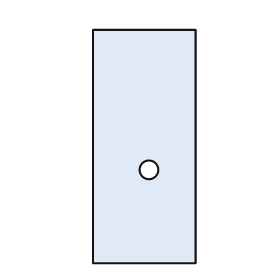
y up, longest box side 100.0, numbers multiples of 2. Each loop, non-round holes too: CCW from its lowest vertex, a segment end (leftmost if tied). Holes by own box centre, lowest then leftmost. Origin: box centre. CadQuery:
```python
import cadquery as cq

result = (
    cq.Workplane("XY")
    .moveTo(-22.0, -50.0)
    .lineTo(22.0, -50.0)
    .lineTo(22.0, 50.0)
    .lineTo(-22.0, 50.0)
    .close()
    .moveTo(2.0, -10.0)
    .circle(4.0)
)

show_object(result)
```